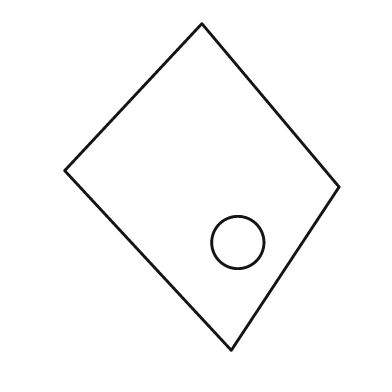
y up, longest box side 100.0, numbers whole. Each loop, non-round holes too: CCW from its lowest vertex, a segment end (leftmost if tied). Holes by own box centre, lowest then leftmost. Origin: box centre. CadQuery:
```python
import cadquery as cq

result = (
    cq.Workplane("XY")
    .moveTo(9.0, -50.0)
    .lineTo(42.0, 0.0)
    .lineTo(0.0, 50.0)
    .lineTo(-42.0, 5.0)
    .close()
    .moveTo(11.0, -17.0)
    .circle(8.0)
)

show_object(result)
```